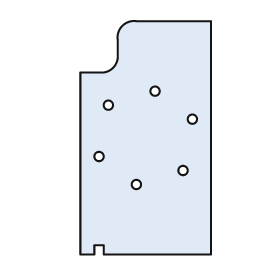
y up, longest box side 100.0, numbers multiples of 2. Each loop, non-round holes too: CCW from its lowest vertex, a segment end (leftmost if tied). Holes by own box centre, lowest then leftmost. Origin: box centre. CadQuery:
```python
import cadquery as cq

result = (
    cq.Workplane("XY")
    .moveTo(-28.0, -50.0)
    .lineTo(-22.0, -50.0)
    .lineTo(-22.0, -46.0)
    .lineTo(-18.0, -46.0)
    .lineTo(-18.0, -50.0)
    .lineTo(28.0, -50.0)
    .lineTo(28.0, 50.0)
    .lineTo(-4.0, 50.0)
    .threePointArc((-10.0, 48.0), (-12.0, 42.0))
    .lineTo(-12.0, 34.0)
    .threePointArc((-14.0, 30.0), (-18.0, 28.0))
    .lineTo(-28.0, 28.0)
    .close()
    .moveTo(-4.0, -20.0)
    .circle(2.0)
    .moveTo(16.0, -14.0)
    .circle(2.0)
    .moveTo(-20.0, -8.0)
    .circle(2.0)
    .moveTo(20.0, 8.0)
    .circle(2.0)
    .moveTo(-16.0, 14.0)
    .circle(2.0)
    .moveTo(4.0, 20.0)
    .circle(2.0)
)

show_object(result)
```